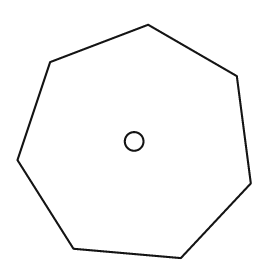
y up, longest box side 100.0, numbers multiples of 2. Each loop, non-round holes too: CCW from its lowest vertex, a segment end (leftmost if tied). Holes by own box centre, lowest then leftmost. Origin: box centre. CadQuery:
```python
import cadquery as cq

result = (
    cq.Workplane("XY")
    .moveTo(20.0, -50.0)
    .lineTo(50.0, -18.0)
    .lineTo(44.0, 28.0)
    .lineTo(6.0, 50.0)
    .lineTo(-36.0, 34.0)
    .lineTo(-50.0, -8.0)
    .lineTo(-26.0, -46.0)
    .close()
    .moveTo(0.0, 0.0)
    .circle(4.0)
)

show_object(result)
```